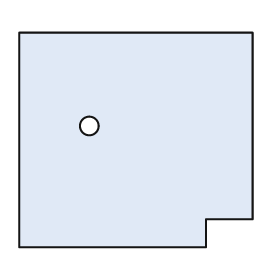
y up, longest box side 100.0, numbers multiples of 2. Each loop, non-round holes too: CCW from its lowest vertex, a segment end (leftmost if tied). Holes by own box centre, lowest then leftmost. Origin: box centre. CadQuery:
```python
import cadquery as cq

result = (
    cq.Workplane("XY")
    .moveTo(-50.0, -46.0)
    .lineTo(30.0, -46.0)
    .lineTo(30.0, -34.0)
    .lineTo(50.0, -34.0)
    .lineTo(50.0, 46.0)
    .lineTo(-50.0, 46.0)
    .close()
    .moveTo(-20.0, 6.0)
    .circle(4.0)
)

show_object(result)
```